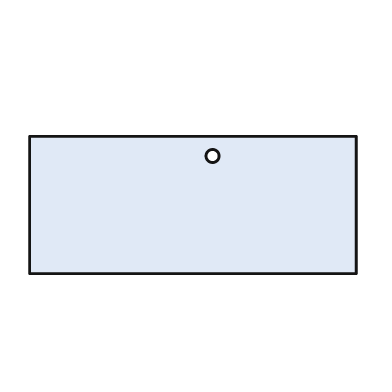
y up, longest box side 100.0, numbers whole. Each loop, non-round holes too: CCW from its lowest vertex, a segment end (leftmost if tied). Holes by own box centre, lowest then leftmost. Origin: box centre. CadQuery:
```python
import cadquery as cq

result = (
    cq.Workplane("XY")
    .moveTo(-50.0, -21.0)
    .lineTo(50.0, -21.0)
    .lineTo(50.0, 21.0)
    .lineTo(-50.0, 21.0)
    .close()
    .moveTo(6.0, 15.0)
    .circle(2.0)
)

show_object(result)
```